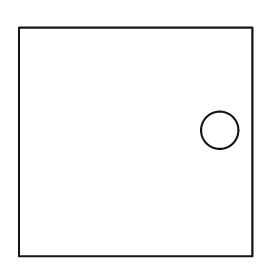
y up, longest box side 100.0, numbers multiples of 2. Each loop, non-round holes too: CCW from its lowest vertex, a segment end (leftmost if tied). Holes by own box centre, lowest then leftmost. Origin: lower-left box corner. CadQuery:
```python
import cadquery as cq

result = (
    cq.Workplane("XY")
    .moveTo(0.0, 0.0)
    .lineTo(100.0, 0.0)
    .lineTo(100.0, 98.0)
    .lineTo(0.0, 98.0)
    .close()
    .moveTo(86.0, 54.0)
    .circle(8.0)
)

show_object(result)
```